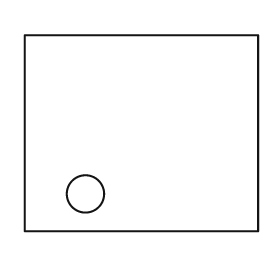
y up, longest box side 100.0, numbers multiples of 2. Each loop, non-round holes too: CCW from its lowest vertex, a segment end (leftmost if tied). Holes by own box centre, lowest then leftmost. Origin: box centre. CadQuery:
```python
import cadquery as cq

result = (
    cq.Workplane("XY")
    .moveTo(-50.0, -42.0)
    .lineTo(50.0, -42.0)
    .lineTo(50.0, 42.0)
    .lineTo(-50.0, 42.0)
    .close()
    .moveTo(-24.0, -26.0)
    .circle(8.0)
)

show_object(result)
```